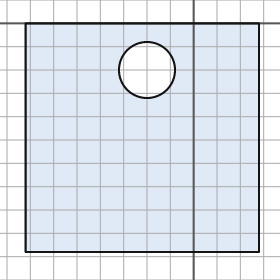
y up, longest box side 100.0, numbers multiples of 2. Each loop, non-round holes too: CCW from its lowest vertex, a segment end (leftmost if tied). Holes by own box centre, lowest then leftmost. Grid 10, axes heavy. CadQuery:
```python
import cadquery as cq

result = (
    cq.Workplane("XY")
    .moveTo(-72.0, -98.0)
    .lineTo(28.0, -98.0)
    .lineTo(28.0, 0.0)
    .lineTo(-72.0, 0.0)
    .close()
    .moveTo(-20.0, -20.0)
    .circle(12.0)
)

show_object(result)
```